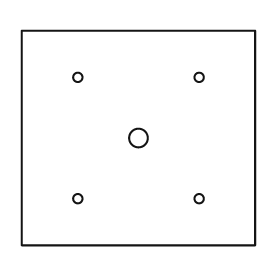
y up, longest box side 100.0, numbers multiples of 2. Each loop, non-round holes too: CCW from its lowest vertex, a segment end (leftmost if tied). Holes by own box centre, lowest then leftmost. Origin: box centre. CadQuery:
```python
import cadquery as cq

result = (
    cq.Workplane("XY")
    .moveTo(-50.0, -46.0)
    .lineTo(50.0, -46.0)
    .lineTo(50.0, 46.0)
    .lineTo(-50.0, 46.0)
    .close()
    .moveTo(-26.0, -26.0)
    .circle(2.0)
    .moveTo(26.0, -26.0)
    .circle(2.0)
    .moveTo(0.0, 0.0)
    .circle(4.0)
    .moveTo(-26.0, 26.0)
    .circle(2.0)
    .moveTo(26.0, 26.0)
    .circle(2.0)
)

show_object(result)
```